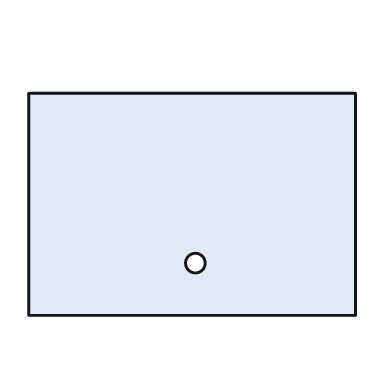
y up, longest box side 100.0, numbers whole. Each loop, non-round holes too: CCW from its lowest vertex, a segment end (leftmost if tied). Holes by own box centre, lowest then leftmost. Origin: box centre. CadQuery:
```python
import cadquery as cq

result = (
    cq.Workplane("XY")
    .moveTo(-50.0, -34.0)
    .lineTo(50.0, -34.0)
    .lineTo(50.0, 34.0)
    .lineTo(-50.0, 34.0)
    .close()
    .moveTo(1.0, -18.0)
    .circle(3.0)
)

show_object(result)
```